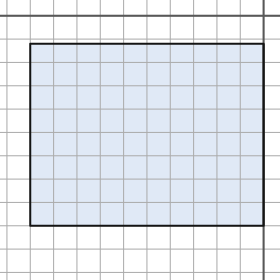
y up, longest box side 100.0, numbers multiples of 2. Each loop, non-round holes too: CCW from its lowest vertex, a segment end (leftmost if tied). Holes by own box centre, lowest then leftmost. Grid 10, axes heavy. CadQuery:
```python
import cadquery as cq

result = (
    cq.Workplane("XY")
    .moveTo(-100.0, -90.0)
    .lineTo(0.0, -90.0)
    .lineTo(0.0, -12.0)
    .lineTo(-100.0, -12.0)
    .close()
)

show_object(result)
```